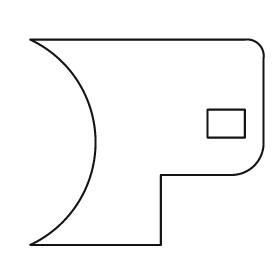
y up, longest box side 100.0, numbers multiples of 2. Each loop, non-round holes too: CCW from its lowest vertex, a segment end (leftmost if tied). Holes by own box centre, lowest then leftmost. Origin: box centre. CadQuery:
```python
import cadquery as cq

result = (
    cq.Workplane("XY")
    .moveTo(-50.0, -44.0)
    .lineTo(6.0, -44.0)
    .lineTo(6.0, -14.0)
    .lineTo(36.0, -14.0)
    .threePointArc((46.0, -10.0), (50.0, 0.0))
    .lineTo(50.0, 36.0)
    .threePointArc((48.0, 42.0), (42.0, 44.0))
    .lineTo(-50.0, 44.0)
    .threePointArc((-22.0, 0.0), (-50.0, -44.0))
    .close()
    .moveTo(26.0, 2.0)
    .lineTo(42.0, 2.0)
    .lineTo(42.0, 14.0)
    .lineTo(26.0, 14.0)
    .close()
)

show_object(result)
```